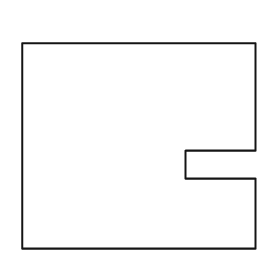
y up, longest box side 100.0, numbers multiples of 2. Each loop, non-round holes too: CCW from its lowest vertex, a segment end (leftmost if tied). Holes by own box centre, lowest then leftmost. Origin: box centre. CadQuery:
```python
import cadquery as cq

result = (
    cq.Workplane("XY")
    .moveTo(-50.0, -44.0)
    .lineTo(50.0, -44.0)
    .lineTo(50.0, -14.0)
    .lineTo(20.0, -14.0)
    .lineTo(20.0, -2.0)
    .lineTo(50.0, -2.0)
    .lineTo(50.0, 44.0)
    .lineTo(-50.0, 44.0)
    .close()
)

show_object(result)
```